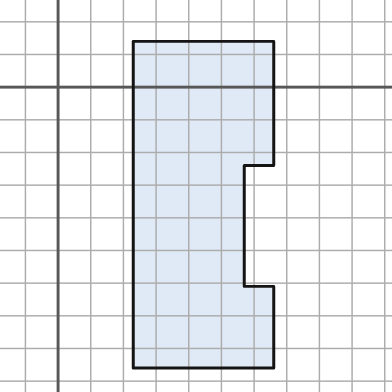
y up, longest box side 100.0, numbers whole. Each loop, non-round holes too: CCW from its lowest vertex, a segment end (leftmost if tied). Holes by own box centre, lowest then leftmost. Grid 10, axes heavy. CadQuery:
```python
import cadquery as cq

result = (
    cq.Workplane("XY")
    .moveTo(23.0, -86.0)
    .lineTo(66.0, -86.0)
    .lineTo(66.0, -61.0)
    .lineTo(57.0, -61.0)
    .lineTo(57.0, -24.0)
    .lineTo(66.0, -24.0)
    .lineTo(66.0, 14.0)
    .lineTo(23.0, 14.0)
    .close()
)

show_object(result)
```